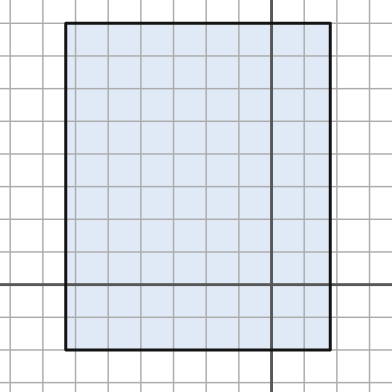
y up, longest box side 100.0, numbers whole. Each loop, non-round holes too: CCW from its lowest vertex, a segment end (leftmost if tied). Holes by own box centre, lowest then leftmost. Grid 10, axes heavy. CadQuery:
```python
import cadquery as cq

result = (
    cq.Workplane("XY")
    .moveTo(-63.0, -20.0)
    .lineTo(18.0, -20.0)
    .lineTo(18.0, 80.0)
    .lineTo(-63.0, 80.0)
    .close()
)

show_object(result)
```